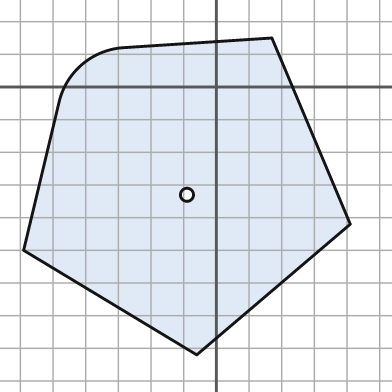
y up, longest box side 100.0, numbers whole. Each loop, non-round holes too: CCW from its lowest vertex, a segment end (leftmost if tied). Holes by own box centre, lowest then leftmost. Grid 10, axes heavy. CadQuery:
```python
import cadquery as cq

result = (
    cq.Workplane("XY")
    .moveTo(-6.0, -82.0)
    .lineTo(41.0, -42.0)
    .lineTo(17.0, 15.0)
    .lineTo(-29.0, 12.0)
    .threePointArc((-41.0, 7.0), (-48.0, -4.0))
    .lineTo(-59.0, -50.0)
    .close()
    .moveTo(-9.0, -33.0)
    .circle(2.0)
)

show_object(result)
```